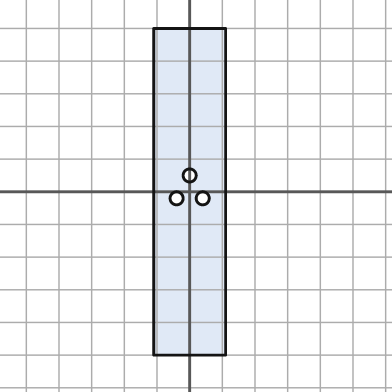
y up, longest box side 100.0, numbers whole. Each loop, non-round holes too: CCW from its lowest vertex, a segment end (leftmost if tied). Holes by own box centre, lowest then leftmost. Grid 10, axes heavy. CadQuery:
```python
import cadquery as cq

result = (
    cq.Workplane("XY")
    .moveTo(-11.0, -50.0)
    .lineTo(11.0, -50.0)
    .lineTo(11.0, 50.0)
    .lineTo(-11.0, 50.0)
    .close()
    .moveTo(-4.0, -2.0)
    .circle(2.0)
    .moveTo(4.0, -2.0)
    .circle(2.0)
    .moveTo(0.0, 5.0)
    .circle(2.0)
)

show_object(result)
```